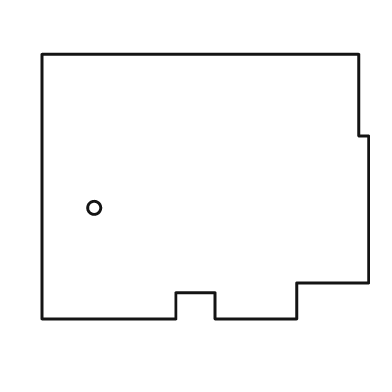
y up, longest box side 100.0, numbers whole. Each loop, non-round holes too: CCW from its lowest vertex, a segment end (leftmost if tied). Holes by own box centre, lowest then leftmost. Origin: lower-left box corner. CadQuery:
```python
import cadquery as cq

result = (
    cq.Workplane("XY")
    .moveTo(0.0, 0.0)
    .lineTo(41.0, 0.0)
    .lineTo(41.0, 8.0)
    .lineTo(53.0, 8.0)
    .lineTo(53.0, 0.0)
    .lineTo(78.0, 0.0)
    .lineTo(78.0, 11.0)
    .lineTo(100.0, 11.0)
    .lineTo(100.0, 56.0)
    .lineTo(97.0, 56.0)
    .lineTo(97.0, 81.0)
    .lineTo(0.0, 81.0)
    .close()
    .moveTo(16.0, 34.0)
    .circle(2.0)
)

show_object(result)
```